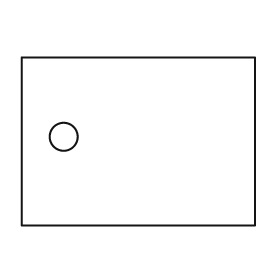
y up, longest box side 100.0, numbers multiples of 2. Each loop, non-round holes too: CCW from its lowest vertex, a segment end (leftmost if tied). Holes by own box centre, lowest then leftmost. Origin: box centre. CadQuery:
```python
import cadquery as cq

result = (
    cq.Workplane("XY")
    .moveTo(-50.0, -36.0)
    .lineTo(50.0, -36.0)
    .lineTo(50.0, 36.0)
    .lineTo(-50.0, 36.0)
    .close()
    .moveTo(-32.0, 2.0)
    .circle(6.0)
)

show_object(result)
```